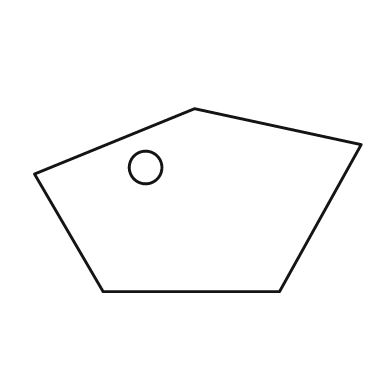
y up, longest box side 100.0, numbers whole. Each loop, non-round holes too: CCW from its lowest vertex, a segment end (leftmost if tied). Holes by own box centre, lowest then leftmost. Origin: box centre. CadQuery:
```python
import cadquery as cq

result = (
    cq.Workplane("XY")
    .moveTo(-29.0, -28.0)
    .lineTo(25.0, -28.0)
    .lineTo(50.0, 17.0)
    .lineTo(-1.0, 28.0)
    .lineTo(-50.0, 8.0)
    .close()
    .moveTo(-16.0, 10.0)
    .circle(5.0)
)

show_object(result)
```